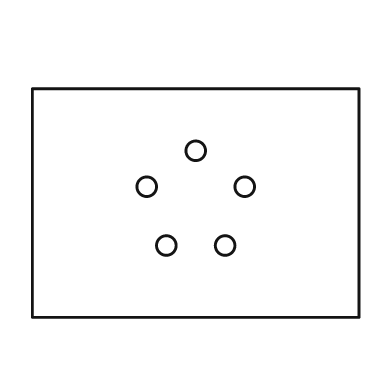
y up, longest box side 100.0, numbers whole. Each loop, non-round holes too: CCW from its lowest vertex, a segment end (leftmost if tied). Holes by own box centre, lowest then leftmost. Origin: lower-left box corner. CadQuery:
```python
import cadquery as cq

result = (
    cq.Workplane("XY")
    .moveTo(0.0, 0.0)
    .lineTo(100.0, 0.0)
    .lineTo(100.0, 70.0)
    .lineTo(0.0, 70.0)
    .close()
    .moveTo(41.0, 22.0)
    .circle(3.0)
    .moveTo(59.0, 22.0)
    .circle(3.0)
    .moveTo(35.0, 40.0)
    .circle(3.0)
    .moveTo(65.0, 40.0)
    .circle(3.0)
    .moveTo(50.0, 51.0)
    .circle(3.0)
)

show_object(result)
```